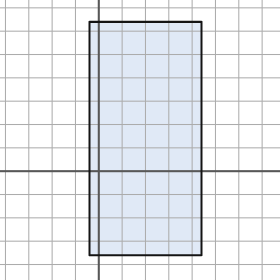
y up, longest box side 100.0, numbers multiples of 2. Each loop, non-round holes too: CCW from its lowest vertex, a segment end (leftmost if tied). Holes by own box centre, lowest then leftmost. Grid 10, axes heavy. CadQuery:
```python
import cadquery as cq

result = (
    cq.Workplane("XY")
    .moveTo(-4.0, -36.0)
    .lineTo(44.0, -36.0)
    .lineTo(44.0, 64.0)
    .lineTo(-4.0, 64.0)
    .close()
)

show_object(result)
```